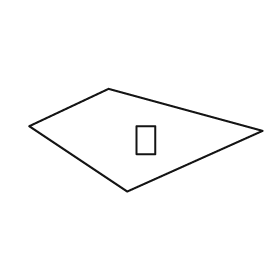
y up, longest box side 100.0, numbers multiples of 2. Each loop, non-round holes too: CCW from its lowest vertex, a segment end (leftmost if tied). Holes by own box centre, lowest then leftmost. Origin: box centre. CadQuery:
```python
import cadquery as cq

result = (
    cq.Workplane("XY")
    .moveTo(-8.0, -22.0)
    .lineTo(50.0, 4.0)
    .lineTo(-16.0, 22.0)
    .lineTo(-50.0, 6.0)
    .close()
    .moveTo(-4.0, -6.0)
    .lineTo(4.0, -6.0)
    .lineTo(4.0, 6.0)
    .lineTo(-4.0, 6.0)
    .close()
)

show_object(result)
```